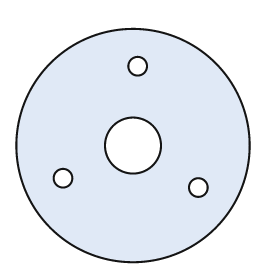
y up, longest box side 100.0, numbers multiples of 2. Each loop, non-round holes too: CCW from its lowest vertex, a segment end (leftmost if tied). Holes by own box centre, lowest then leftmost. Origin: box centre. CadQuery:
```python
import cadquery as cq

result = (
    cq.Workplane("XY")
    .moveTo(0.0, 0.0)
    .circle(50.0)
    .moveTo(28.0, -18.0)
    .circle(4.0)
    .moveTo(-30.0, -14.0)
    .circle(4.0)
    .moveTo(0.0, 0.0)
    .circle(12.0)
    .moveTo(2.0, 34.0)
    .circle(4.0)
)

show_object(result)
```